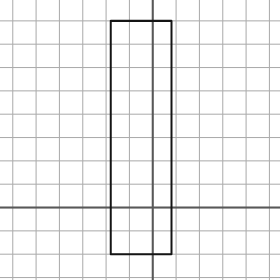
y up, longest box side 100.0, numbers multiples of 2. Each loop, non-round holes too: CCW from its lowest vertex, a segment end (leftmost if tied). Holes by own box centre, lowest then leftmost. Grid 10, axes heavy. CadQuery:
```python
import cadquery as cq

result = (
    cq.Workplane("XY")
    .moveTo(-18.0, -20.0)
    .lineTo(8.0, -20.0)
    .lineTo(8.0, 80.0)
    .lineTo(-18.0, 80.0)
    .close()
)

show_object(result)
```